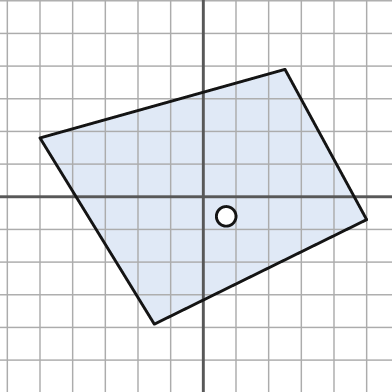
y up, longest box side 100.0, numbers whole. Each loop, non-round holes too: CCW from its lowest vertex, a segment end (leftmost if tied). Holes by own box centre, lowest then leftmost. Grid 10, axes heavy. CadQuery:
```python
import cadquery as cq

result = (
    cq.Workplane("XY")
    .moveTo(-15.0, -39.0)
    .lineTo(50.0, -7.0)
    .lineTo(25.0, 39.0)
    .lineTo(-50.0, 18.0)
    .close()
    .moveTo(7.0, -6.0)
    .circle(3.0)
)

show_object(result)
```